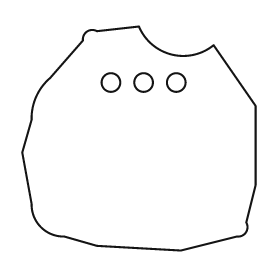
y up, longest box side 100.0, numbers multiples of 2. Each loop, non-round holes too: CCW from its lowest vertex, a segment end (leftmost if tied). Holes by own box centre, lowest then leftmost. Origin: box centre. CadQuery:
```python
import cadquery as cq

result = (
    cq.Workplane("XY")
    .moveTo(18.0, -48.0)
    .lineTo(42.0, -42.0)
    .threePointArc((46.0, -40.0), (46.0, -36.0))
    .lineTo(50.0, -20.0)
    .lineTo(50.0, 14.0)
    .lineTo(32.0, 40.0)
    .threePointArc((14.0, 36.0), (0.0, 48.0))
    .lineTo(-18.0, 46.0)
    .threePointArc((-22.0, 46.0), (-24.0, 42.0))
    .lineTo(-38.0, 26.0)
    .threePointArc((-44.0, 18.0), (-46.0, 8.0))
    .lineTo(-50.0, -6.0)
    .lineTo(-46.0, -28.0)
    .threePointArc((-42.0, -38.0), (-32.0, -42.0))
    .lineTo(-18.0, -46.0)
    .close()
    .moveTo(-12.0, 24.0)
    .circle(4.0)
    .moveTo(2.0, 24.0)
    .circle(4.0)
    .moveTo(16.0, 24.0)
    .circle(4.0)
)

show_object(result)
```